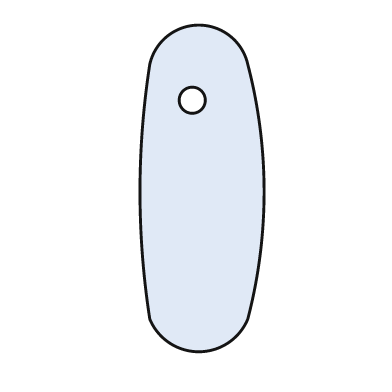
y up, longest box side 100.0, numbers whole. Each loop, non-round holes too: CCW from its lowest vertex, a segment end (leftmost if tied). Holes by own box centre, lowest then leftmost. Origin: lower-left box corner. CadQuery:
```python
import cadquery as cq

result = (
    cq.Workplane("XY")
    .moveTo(3.0, 10.0)
    .threePointArc((18.0, 0.0), (33.0, 10.0))
    .threePointArc((38.0, 49.0), (33.0, 88.0))
    .threePointArc((18.0, 100.0), (3.0, 88.0))
    .threePointArc((0.0, 49.0), (3.0, 10.0))
    .close()
    .moveTo(16.0, 77.0)
    .circle(4.0)
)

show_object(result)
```